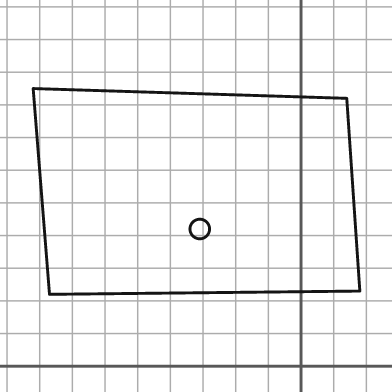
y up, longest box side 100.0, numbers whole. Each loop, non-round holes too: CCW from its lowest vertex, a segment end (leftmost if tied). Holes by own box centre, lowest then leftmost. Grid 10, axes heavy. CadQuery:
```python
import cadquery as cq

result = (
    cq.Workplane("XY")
    .moveTo(-77.0, 22.0)
    .lineTo(18.0, 23.0)
    .lineTo(14.0, 82.0)
    .lineTo(-82.0, 85.0)
    .close()
    .moveTo(-31.0, 42.0)
    .circle(3.0)
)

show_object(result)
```